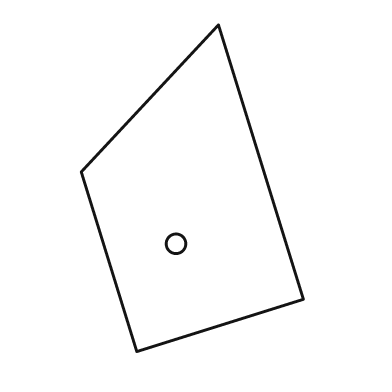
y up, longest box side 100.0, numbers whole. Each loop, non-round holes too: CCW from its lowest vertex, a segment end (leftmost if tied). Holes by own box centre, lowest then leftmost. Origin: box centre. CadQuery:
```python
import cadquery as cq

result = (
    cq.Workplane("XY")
    .moveTo(-17.0, -50.0)
    .lineTo(34.0, -34.0)
    .lineTo(8.0, 50.0)
    .lineTo(-34.0, 5.0)
    .close()
    .moveTo(-5.0, -17.0)
    .circle(3.0)
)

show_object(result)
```